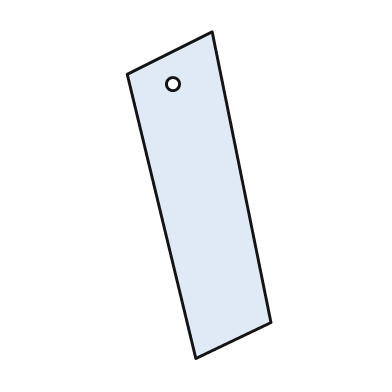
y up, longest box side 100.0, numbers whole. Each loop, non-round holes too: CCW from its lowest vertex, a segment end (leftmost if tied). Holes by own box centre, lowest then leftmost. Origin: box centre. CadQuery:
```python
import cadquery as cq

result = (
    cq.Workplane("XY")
    .moveTo(-1.0, -50.0)
    .lineTo(22.0, -39.0)
    .lineTo(4.0, 50.0)
    .lineTo(-22.0, 37.0)
    .close()
    .moveTo(-8.0, 34.0)
    .circle(2.0)
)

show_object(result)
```